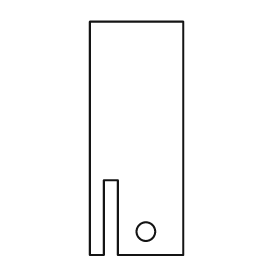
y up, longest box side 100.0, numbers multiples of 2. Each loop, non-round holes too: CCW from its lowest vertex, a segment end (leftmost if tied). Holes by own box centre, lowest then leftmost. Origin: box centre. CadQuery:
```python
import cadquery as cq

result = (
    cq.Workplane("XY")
    .moveTo(-20.0, -50.0)
    .lineTo(-14.0, -50.0)
    .lineTo(-14.0, -18.0)
    .lineTo(-8.0, -18.0)
    .lineTo(-8.0, -50.0)
    .lineTo(20.0, -50.0)
    .lineTo(20.0, 50.0)
    .lineTo(-20.0, 50.0)
    .close()
    .moveTo(4.0, -40.0)
    .circle(4.0)
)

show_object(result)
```